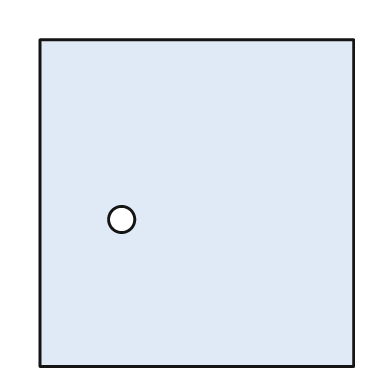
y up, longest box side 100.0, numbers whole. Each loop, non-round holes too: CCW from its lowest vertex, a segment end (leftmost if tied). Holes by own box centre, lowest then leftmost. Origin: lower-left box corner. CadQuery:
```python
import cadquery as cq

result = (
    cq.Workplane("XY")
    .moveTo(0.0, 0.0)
    .lineTo(96.0, 0.0)
    .lineTo(96.0, 100.0)
    .lineTo(0.0, 100.0)
    .close()
    .moveTo(25.0, 45.0)
    .circle(4.0)
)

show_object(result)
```